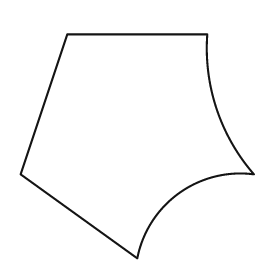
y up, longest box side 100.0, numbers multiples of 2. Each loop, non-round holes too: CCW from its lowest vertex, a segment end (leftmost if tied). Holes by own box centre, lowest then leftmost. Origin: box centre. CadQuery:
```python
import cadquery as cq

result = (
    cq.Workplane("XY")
    .moveTo(0.0, -48.0)
    .threePointArc((18.0, -20.0), (50.0, -12.0))
    .threePointArc((34.0, 16.0), (30.0, 48.0))
    .lineTo(-30.0, 48.0)
    .lineTo(-50.0, -12.0)
    .close()
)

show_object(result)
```